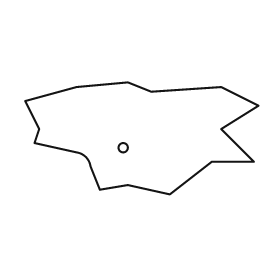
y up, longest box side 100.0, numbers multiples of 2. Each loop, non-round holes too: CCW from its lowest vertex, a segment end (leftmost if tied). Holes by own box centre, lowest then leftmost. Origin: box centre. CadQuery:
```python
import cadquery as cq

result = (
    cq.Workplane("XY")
    .moveTo(12.0, -24.0)
    .lineTo(30.0, -10.0)
    .lineTo(48.0, -10.0)
    .lineTo(34.0, 4.0)
    .lineTo(50.0, 14.0)
    .lineTo(34.0, 22.0)
    .lineTo(4.0, 20.0)
    .lineTo(-6.0, 24.0)
    .lineTo(-28.0, 22.0)
    .lineTo(-50.0, 16.0)
    .lineTo(-44.0, 4.0)
    .lineTo(-46.0, -2.0)
    .lineTo(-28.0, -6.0)
    .threePointArc((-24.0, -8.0), (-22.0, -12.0))
    .lineTo(-18.0, -22.0)
    .lineTo(-6.0, -20.0)
    .close()
    .moveTo(-8.0, -4.0)
    .circle(2.0)
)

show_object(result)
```